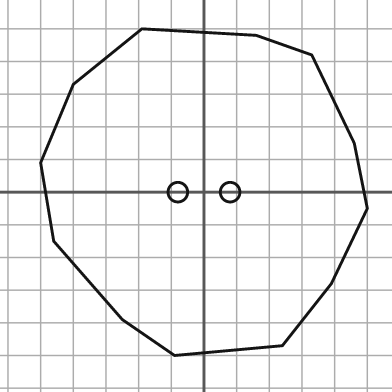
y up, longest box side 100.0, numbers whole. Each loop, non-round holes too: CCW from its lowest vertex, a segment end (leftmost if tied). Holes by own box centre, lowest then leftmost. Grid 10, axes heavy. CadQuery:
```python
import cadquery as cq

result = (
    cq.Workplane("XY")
    .moveTo(-9.0, -50.0)
    .lineTo(24.0, -47.0)
    .lineTo(39.0, -28.0)
    .lineTo(50.0, -5.0)
    .lineTo(46.0, 15.0)
    .lineTo(33.0, 42.0)
    .lineTo(16.0, 48.0)
    .lineTo(-19.0, 50.0)
    .lineTo(-40.0, 33.0)
    .lineTo(-50.0, 9.0)
    .lineTo(-46.0, -15.0)
    .lineTo(-25.0, -39.0)
    .close()
    .moveTo(-8.0, 0.0)
    .circle(3.0)
    .moveTo(8.0, 0.0)
    .circle(3.0)
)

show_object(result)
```